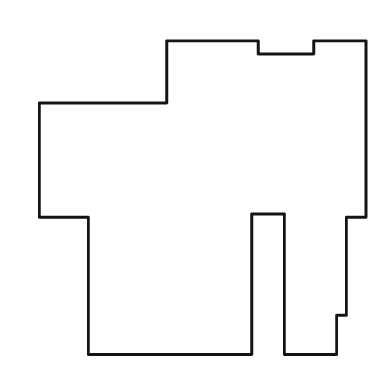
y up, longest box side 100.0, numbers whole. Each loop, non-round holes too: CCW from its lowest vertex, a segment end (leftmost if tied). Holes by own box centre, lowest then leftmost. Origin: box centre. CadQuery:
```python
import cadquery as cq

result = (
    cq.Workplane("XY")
    .moveTo(-35.0, -48.0)
    .lineTo(15.0, -48.0)
    .lineTo(15.0, -5.0)
    .lineTo(25.0, -5.0)
    .lineTo(25.0, -48.0)
    .lineTo(41.0, -48.0)
    .lineTo(41.0, -36.0)
    .lineTo(44.0, -36.0)
    .lineTo(44.0, -6.0)
    .lineTo(50.0, -6.0)
    .lineTo(50.0, 48.0)
    .lineTo(34.0, 48.0)
    .lineTo(34.0, 44.0)
    .lineTo(17.0, 44.0)
    .lineTo(17.0, 48.0)
    .lineTo(-11.0, 48.0)
    .lineTo(-11.0, 29.0)
    .lineTo(-50.0, 29.0)
    .lineTo(-50.0, -6.0)
    .lineTo(-35.0, -6.0)
    .close()
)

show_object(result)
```